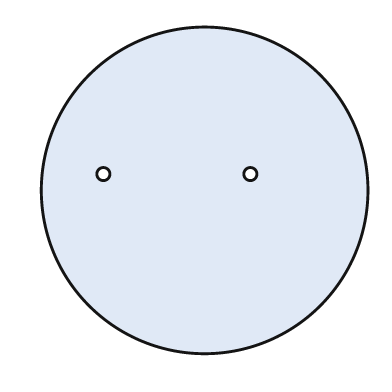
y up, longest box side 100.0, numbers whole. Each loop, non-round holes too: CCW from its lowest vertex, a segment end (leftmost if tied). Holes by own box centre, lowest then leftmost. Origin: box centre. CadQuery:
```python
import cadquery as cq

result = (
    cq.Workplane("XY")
    .moveTo(0.0, 0.0)
    .circle(50.0)
    .moveTo(-31.0, 5.0)
    .circle(2.0)
    .moveTo(14.0, 5.0)
    .circle(2.0)
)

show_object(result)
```